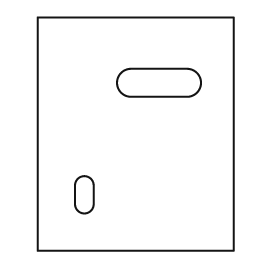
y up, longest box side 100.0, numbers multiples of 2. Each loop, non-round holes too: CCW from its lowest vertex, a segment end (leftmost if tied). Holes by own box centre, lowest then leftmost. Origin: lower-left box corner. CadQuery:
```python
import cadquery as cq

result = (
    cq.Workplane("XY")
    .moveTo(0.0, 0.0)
    .lineTo(84.0, 0.0)
    .lineTo(84.0, 100.0)
    .lineTo(0.0, 100.0)
    .close()
    .moveTo(16.0, 20.0)
    .threePointArc((20.0, 16.0), (24.0, 20.0))
    .lineTo(24.0, 28.0)
    .threePointArc((20.0, 32.0), (16.0, 28.0))
    .close()
    .moveTo(40.0, 66.0)
    .lineTo(64.0, 66.0)
    .threePointArc((70.0, 72.0), (64.0, 78.0))
    .lineTo(40.0, 78.0)
    .threePointArc((34.0, 72.0), (40.0, 66.0))
    .close()
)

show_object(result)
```